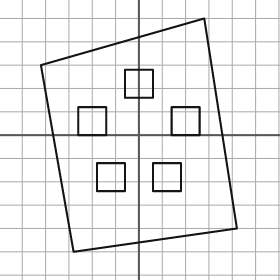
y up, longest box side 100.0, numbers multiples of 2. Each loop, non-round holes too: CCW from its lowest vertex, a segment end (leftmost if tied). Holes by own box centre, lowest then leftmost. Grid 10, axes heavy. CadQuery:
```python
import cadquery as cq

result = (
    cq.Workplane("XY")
    .moveTo(-28.0, -50.0)
    .lineTo(42.0, -40.0)
    .lineTo(28.0, 50.0)
    .lineTo(-42.0, 30.0)
    .close()
    .moveTo(-18.0, -24.0)
    .lineTo(-6.0, -24.0)
    .lineTo(-6.0, -12.0)
    .lineTo(-18.0, -12.0)
    .close()
    .moveTo(6.0, -24.0)
    .lineTo(18.0, -24.0)
    .lineTo(18.0, -12.0)
    .lineTo(6.0, -12.0)
    .close()
    .moveTo(-26.0, 0.0)
    .lineTo(-14.0, 0.0)
    .lineTo(-14.0, 12.0)
    .lineTo(-26.0, 12.0)
    .close()
    .moveTo(14.0, 0.0)
    .lineTo(26.0, 0.0)
    .lineTo(26.0, 12.0)
    .lineTo(14.0, 12.0)
    .close()
    .moveTo(-6.0, 16.0)
    .lineTo(6.0, 16.0)
    .lineTo(6.0, 28.0)
    .lineTo(-6.0, 28.0)
    .close()
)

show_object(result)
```